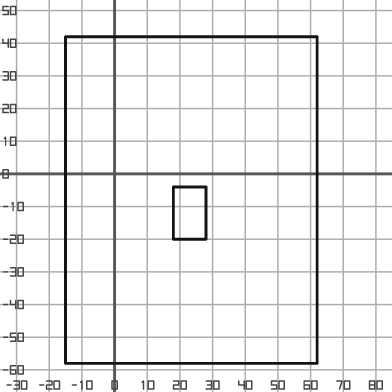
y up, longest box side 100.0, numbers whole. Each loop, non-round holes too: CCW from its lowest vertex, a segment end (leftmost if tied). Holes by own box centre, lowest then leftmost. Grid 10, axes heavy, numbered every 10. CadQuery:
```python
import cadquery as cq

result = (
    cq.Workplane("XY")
    .moveTo(-15.0, -58.0)
    .lineTo(62.0, -58.0)
    .lineTo(62.0, 42.0)
    .lineTo(-15.0, 42.0)
    .close()
    .moveTo(18.0, -20.0)
    .lineTo(28.0, -20.0)
    .lineTo(28.0, -4.0)
    .lineTo(18.0, -4.0)
    .close()
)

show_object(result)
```